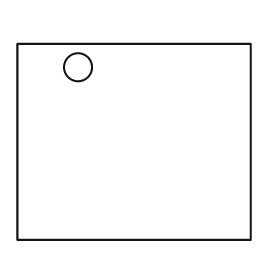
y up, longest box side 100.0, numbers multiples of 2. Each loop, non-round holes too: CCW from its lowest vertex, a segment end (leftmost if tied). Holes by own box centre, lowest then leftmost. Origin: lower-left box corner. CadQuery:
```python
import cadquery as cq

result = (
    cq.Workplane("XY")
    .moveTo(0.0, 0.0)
    .lineTo(100.0, 0.0)
    .lineTo(100.0, 84.0)
    .lineTo(0.0, 84.0)
    .close()
    .moveTo(26.0, 74.0)
    .circle(6.0)
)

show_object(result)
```